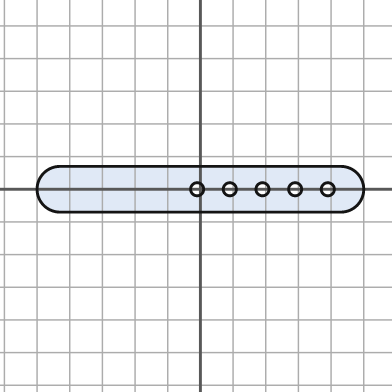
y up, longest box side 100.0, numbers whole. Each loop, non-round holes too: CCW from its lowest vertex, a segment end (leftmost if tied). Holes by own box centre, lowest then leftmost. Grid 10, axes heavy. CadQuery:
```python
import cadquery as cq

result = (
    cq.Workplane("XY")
    .moveTo(-43.0, -7.0)
    .lineTo(43.0, -7.0)
    .threePointArc((50.0, 0.0), (43.0, 7.0))
    .lineTo(-43.0, 7.0)
    .threePointArc((-50.0, 0.0), (-43.0, -7.0))
    .close()
    .moveTo(-1.0, 0.0)
    .circle(2.0)
    .moveTo(9.0, 0.0)
    .circle(2.0)
    .moveTo(19.0, 0.0)
    .circle(2.0)
    .moveTo(29.0, 0.0)
    .circle(2.0)
    .moveTo(39.0, 0.0)
    .circle(2.0)
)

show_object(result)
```